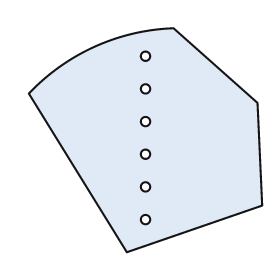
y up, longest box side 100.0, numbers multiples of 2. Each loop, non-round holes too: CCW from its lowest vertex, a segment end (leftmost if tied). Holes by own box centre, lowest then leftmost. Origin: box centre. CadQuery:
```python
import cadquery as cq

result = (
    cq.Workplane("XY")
    .moveTo(-8.0, -48.0)
    .lineTo(50.0, -28.0)
    .lineTo(48.0, 16.0)
    .lineTo(12.0, 48.0)
    .threePointArc((-22.0, 40.0), (-50.0, 20.0))
    .close()
    .moveTo(0.0, -34.0)
    .circle(2.0)
    .moveTo(0.0, -20.0)
    .circle(2.0)
    .moveTo(0.0, -6.0)
    .circle(2.0)
    .moveTo(0.0, 8.0)
    .circle(2.0)
    .moveTo(0.0, 22.0)
    .circle(2.0)
    .moveTo(0.0, 36.0)
    .circle(2.0)
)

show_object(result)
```